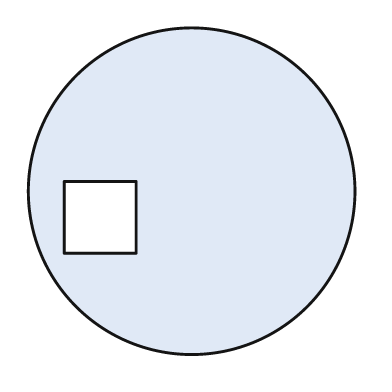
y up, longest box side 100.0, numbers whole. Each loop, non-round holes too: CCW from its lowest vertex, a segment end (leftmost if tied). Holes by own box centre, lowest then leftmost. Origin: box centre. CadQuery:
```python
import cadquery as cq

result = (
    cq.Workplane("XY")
    .moveTo(0.0, 0.0)
    .circle(50.0)
    .moveTo(-39.0, -19.0)
    .lineTo(-17.0, -19.0)
    .lineTo(-17.0, 3.0)
    .lineTo(-39.0, 3.0)
    .close()
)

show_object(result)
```